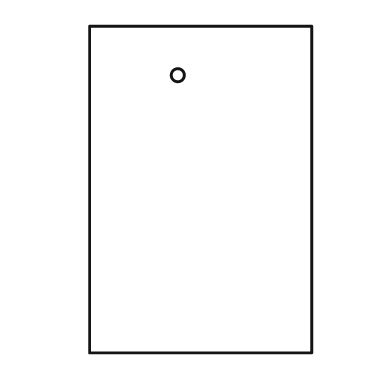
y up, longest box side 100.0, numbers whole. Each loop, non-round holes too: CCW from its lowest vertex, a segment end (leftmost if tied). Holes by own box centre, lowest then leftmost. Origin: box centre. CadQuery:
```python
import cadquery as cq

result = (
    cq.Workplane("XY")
    .moveTo(-34.0, -50.0)
    .lineTo(34.0, -50.0)
    .lineTo(34.0, 50.0)
    .lineTo(-34.0, 50.0)
    .close()
    .moveTo(-7.0, 35.0)
    .circle(2.0)
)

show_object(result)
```